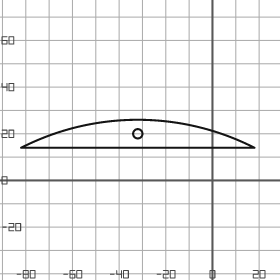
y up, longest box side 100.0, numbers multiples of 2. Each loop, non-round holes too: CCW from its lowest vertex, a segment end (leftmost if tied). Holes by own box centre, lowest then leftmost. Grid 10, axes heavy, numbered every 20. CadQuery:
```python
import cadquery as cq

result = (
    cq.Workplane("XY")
    .moveTo(-82.0, 14.0)
    .lineTo(18.0, 14.0)
    .threePointArc((-32.0, 26.0), (-82.0, 14.0))
    .close()
    .moveTo(-32.0, 20.0)
    .circle(2.0)
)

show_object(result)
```